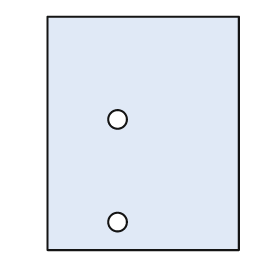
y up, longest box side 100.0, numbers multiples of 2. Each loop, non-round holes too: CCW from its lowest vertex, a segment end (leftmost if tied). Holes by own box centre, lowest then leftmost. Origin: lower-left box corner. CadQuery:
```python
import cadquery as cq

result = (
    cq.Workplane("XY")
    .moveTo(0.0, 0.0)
    .lineTo(82.0, 0.0)
    .lineTo(82.0, 100.0)
    .lineTo(0.0, 100.0)
    .close()
    .moveTo(30.0, 12.0)
    .circle(4.0)
    .moveTo(30.0, 56.0)
    .circle(4.0)
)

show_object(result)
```